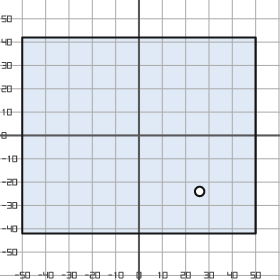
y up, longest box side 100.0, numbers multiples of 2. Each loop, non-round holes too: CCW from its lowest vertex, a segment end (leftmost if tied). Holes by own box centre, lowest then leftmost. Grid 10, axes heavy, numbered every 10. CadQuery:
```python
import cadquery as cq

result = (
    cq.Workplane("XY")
    .moveTo(-50.0, -42.0)
    .lineTo(50.0, -42.0)
    .lineTo(50.0, 42.0)
    .lineTo(-50.0, 42.0)
    .close()
    .moveTo(26.0, -24.0)
    .circle(2.0)
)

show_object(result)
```